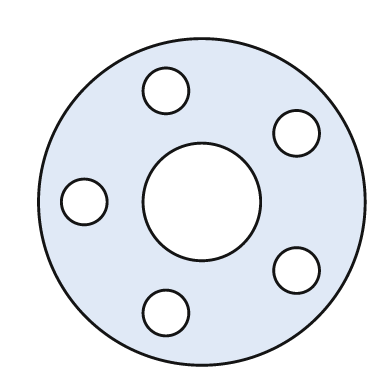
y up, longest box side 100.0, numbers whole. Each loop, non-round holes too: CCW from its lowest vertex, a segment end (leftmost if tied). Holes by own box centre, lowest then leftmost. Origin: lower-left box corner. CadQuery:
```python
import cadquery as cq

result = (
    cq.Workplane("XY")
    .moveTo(50.0, 50.0)
    .circle(50.0)
    .moveTo(39.0, 16.0)
    .circle(7.0)
    .moveTo(79.0, 29.0)
    .circle(7.0)
    .moveTo(14.0, 50.0)
    .circle(7.0)
    .moveTo(50.0, 50.0)
    .circle(18.0)
    .moveTo(79.0, 71.0)
    .circle(7.0)
    .moveTo(39.0, 84.0)
    .circle(7.0)
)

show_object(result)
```